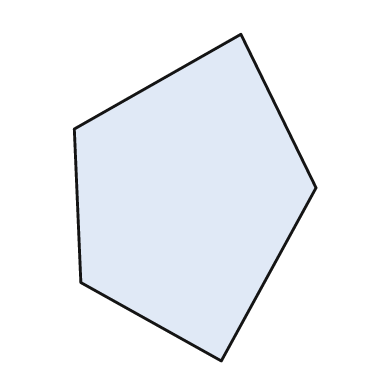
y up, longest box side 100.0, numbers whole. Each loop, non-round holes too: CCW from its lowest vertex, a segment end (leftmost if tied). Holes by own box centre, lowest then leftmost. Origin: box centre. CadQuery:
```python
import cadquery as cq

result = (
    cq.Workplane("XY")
    .moveTo(8.0, -50.0)
    .lineTo(37.0, 3.0)
    .lineTo(14.0, 50.0)
    .lineTo(-37.0, 21.0)
    .lineTo(-35.0, -26.0)
    .close()
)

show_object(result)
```